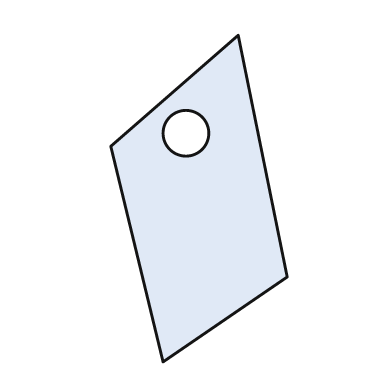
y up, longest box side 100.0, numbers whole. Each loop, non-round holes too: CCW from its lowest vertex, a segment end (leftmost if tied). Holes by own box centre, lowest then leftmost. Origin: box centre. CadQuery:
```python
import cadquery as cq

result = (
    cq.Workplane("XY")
    .moveTo(-11.0, -50.0)
    .lineTo(27.0, -24.0)
    .lineTo(12.0, 50.0)
    .lineTo(-27.0, 16.0)
    .close()
    .moveTo(-4.0, 20.0)
    .circle(7.0)
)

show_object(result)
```